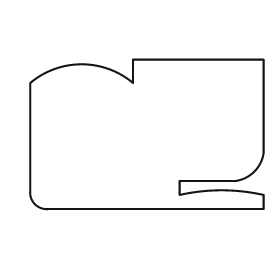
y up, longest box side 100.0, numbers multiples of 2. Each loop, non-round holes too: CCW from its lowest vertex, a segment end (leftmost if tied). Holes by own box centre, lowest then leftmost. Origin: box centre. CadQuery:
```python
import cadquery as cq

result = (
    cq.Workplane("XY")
    .moveTo(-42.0, -32.0)
    .lineTo(50.0, -32.0)
    .lineTo(50.0, -26.0)
    .threePointArc((32.0, -24.0), (14.0, -26.0))
    .lineTo(14.0, -20.0)
    .lineTo(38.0, -20.0)
    .threePointArc((46.0, -16.0), (50.0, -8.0))
    .lineTo(50.0, 32.0)
    .lineTo(-6.0, 32.0)
    .lineTo(-6.0, 22.0)
    .threePointArc((-28.0, 30.0), (-50.0, 22.0))
    .lineTo(-50.0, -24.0)
    .threePointArc((-48.0, -30.0), (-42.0, -32.0))
    .close()
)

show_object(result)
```